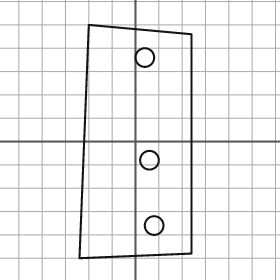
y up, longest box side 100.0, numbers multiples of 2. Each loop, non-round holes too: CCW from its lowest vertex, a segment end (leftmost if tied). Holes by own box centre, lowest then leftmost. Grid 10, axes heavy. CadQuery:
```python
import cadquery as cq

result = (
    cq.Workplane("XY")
    .moveTo(-24.0, -50.0)
    .lineTo(24.0, -48.0)
    .lineTo(24.0, 46.0)
    .lineTo(-20.0, 50.0)
    .close()
    .moveTo(8.0, -36.0)
    .circle(4.0)
    .moveTo(6.0, -8.0)
    .circle(4.0)
    .moveTo(4.0, 36.0)
    .circle(4.0)
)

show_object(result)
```